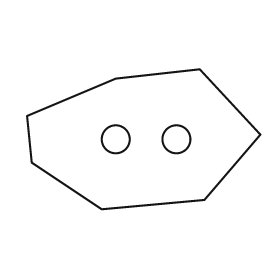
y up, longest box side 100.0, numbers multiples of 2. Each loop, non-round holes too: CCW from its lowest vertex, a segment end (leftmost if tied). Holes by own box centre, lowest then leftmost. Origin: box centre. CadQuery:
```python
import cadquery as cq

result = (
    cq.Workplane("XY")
    .moveTo(-18.0, -30.0)
    .lineTo(26.0, -26.0)
    .lineTo(50.0, 2.0)
    .lineTo(24.0, 30.0)
    .lineTo(-12.0, 26.0)
    .lineTo(-50.0, 10.0)
    .lineTo(-48.0, -10.0)
    .close()
    .moveTo(-12.0, 0.0)
    .circle(6.0)
    .moveTo(14.0, 0.0)
    .circle(6.0)
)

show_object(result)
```